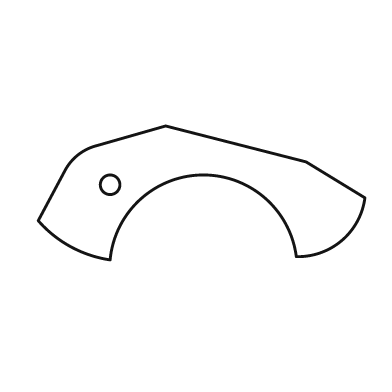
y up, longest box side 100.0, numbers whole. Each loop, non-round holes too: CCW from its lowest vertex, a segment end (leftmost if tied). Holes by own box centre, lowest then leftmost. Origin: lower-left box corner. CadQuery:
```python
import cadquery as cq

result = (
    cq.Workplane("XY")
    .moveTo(22.0, 0.0)
    .threePointArc((50.0, 26.0), (79.0, 1.0))
    .threePointArc((93.0, 6.0), (100.0, 19.0))
    .lineTo(82.0, 30.0)
    .lineTo(39.0, 41.0)
    .lineTo(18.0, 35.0)
    .threePointArc((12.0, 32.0), (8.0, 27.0))
    .lineTo(0.0, 12.0)
    .threePointArc((10.0, 4.0), (22.0, 0.0))
    .close()
    .moveTo(22.0, 23.0)
    .circle(3.0)
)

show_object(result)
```